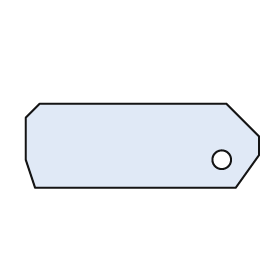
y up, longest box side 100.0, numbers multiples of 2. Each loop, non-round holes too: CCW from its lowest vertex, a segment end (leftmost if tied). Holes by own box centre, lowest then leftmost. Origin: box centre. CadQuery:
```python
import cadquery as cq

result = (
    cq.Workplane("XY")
    .moveTo(-46.0, -18.0)
    .lineTo(40.0, -18.0)
    .lineTo(50.0, -4.0)
    .lineTo(50.0, 4.0)
    .lineTo(36.0, 18.0)
    .lineTo(-44.0, 18.0)
    .lineTo(-50.0, 12.0)
    .lineTo(-50.0, -6.0)
    .close()
    .moveTo(34.0, -6.0)
    .circle(4.0)
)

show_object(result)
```